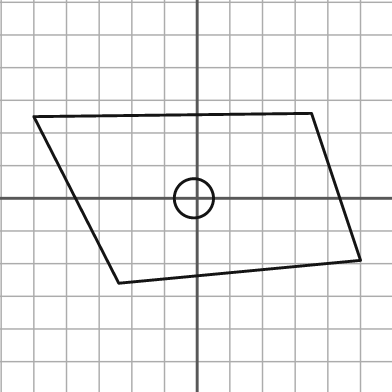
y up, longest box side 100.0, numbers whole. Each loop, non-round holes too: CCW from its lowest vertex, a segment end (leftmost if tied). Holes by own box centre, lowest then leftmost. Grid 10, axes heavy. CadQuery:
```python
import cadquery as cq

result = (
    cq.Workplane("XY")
    .moveTo(-24.0, -26.0)
    .lineTo(50.0, -19.0)
    .lineTo(35.0, 26.0)
    .lineTo(-50.0, 25.0)
    .close()
    .moveTo(-1.0, 0.0)
    .circle(6.0)
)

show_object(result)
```